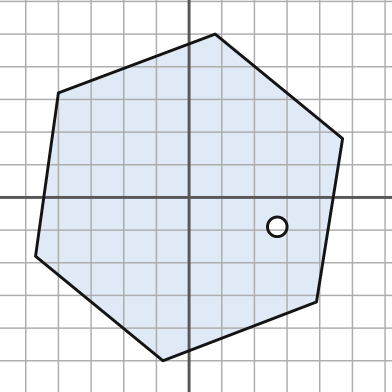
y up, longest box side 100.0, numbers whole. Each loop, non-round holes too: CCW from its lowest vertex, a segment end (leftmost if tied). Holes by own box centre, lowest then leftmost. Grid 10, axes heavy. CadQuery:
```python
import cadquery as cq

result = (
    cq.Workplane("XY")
    .moveTo(-8.0, -50.0)
    .lineTo(39.0, -32.0)
    .lineTo(47.0, 18.0)
    .lineTo(8.0, 50.0)
    .lineTo(-40.0, 32.0)
    .lineTo(-47.0, -18.0)
    .close()
    .moveTo(27.0, -9.0)
    .circle(3.0)
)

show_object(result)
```